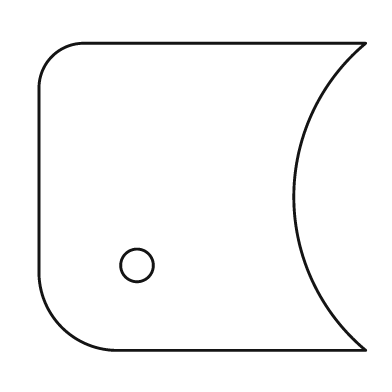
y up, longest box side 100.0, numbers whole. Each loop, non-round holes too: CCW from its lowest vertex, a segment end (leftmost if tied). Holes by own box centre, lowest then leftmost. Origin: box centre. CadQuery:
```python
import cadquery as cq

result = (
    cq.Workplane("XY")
    .moveTo(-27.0, -47.0)
    .lineTo(50.0, -47.0)
    .threePointArc((28.0, 0.0), (50.0, 47.0))
    .lineTo(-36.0, 47.0)
    .threePointArc((-46.0, 43.0), (-50.0, 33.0))
    .lineTo(-50.0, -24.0)
    .threePointArc((-43.0, -40.0), (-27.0, -47.0))
    .close()
    .moveTo(-20.0, -21.0)
    .circle(5.0)
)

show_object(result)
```